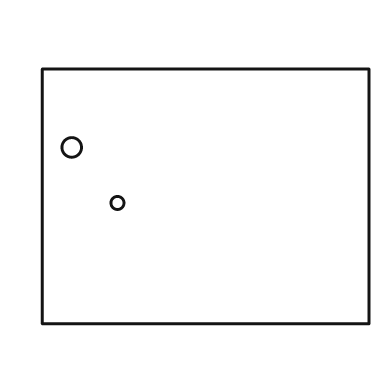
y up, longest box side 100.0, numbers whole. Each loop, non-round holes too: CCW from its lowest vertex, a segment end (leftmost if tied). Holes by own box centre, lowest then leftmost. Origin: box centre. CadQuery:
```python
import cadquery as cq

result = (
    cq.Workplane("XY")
    .moveTo(-50.0, -39.0)
    .lineTo(50.0, -39.0)
    .lineTo(50.0, 39.0)
    .lineTo(-50.0, 39.0)
    .close()
    .moveTo(-27.0, -2.0)
    .circle(2.0)
    .moveTo(-41.0, 15.0)
    .circle(3.0)
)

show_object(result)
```